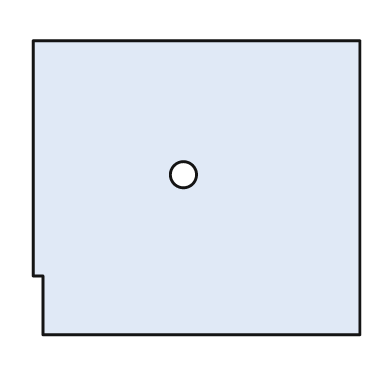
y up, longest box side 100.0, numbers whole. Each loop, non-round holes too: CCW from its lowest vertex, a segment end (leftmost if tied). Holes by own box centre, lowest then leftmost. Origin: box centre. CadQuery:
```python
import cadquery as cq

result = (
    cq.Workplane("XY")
    .moveTo(-47.0, -45.0)
    .lineTo(50.0, -45.0)
    .lineTo(50.0, 45.0)
    .lineTo(-50.0, 45.0)
    .lineTo(-50.0, -27.0)
    .lineTo(-47.0, -27.0)
    .close()
    .moveTo(-4.0, 4.0)
    .circle(4.0)
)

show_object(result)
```